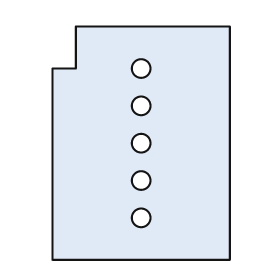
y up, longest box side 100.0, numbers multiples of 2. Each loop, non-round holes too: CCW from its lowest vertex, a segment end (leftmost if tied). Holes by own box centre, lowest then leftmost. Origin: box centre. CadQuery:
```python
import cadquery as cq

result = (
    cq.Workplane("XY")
    .moveTo(-38.0, -50.0)
    .lineTo(38.0, -50.0)
    .lineTo(38.0, 50.0)
    .lineTo(-28.0, 50.0)
    .lineTo(-28.0, 32.0)
    .lineTo(-38.0, 32.0)
    .close()
    .moveTo(0.0, -32.0)
    .circle(4.0)
    .moveTo(0.0, -16.0)
    .circle(4.0)
    .moveTo(0.0, 0.0)
    .circle(4.0)
    .moveTo(0.0, 16.0)
    .circle(4.0)
    .moveTo(0.0, 32.0)
    .circle(4.0)
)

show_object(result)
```